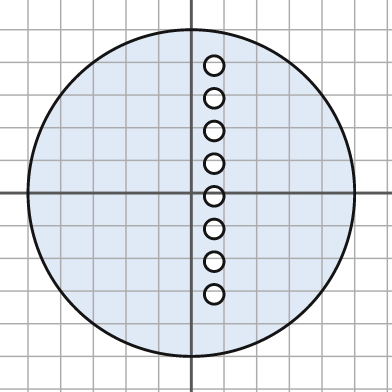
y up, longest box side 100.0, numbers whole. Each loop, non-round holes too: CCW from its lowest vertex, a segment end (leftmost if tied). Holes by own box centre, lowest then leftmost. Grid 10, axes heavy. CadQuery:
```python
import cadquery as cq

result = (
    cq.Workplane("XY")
    .moveTo(0.0, 0.0)
    .circle(50.0)
    .moveTo(7.0, -31.0)
    .circle(3.0)
    .moveTo(7.0, -21.0)
    .circle(3.0)
    .moveTo(7.0, -11.0)
    .circle(3.0)
    .moveTo(7.0, -1.0)
    .circle(3.0)
    .moveTo(7.0, 9.0)
    .circle(3.0)
    .moveTo(7.0, 19.0)
    .circle(3.0)
    .moveTo(7.0, 29.0)
    .circle(3.0)
    .moveTo(7.0, 39.0)
    .circle(3.0)
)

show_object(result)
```